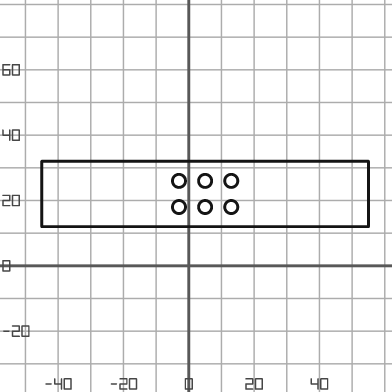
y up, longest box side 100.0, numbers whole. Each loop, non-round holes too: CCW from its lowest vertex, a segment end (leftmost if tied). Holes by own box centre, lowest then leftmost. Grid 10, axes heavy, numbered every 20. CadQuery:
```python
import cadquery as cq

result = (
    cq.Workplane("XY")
    .moveTo(-45.0, 12.0)
    .lineTo(55.0, 12.0)
    .lineTo(55.0, 32.0)
    .lineTo(-45.0, 32.0)
    .close()
    .moveTo(-3.0, 18.0)
    .circle(2.0)
    .moveTo(5.0, 18.0)
    .circle(2.0)
    .moveTo(13.0, 18.0)
    .circle(2.0)
    .moveTo(-3.0, 26.0)
    .circle(2.0)
    .moveTo(5.0, 26.0)
    .circle(2.0)
    .moveTo(13.0, 26.0)
    .circle(2.0)
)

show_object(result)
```